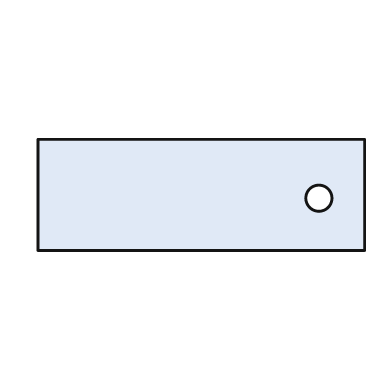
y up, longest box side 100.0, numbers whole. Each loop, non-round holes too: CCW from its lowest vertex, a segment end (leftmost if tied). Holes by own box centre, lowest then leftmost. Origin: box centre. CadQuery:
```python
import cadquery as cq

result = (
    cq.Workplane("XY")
    .moveTo(-50.0, -17.0)
    .lineTo(50.0, -17.0)
    .lineTo(50.0, 17.0)
    .lineTo(-50.0, 17.0)
    .close()
    .moveTo(36.0, -1.0)
    .circle(4.0)
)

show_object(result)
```